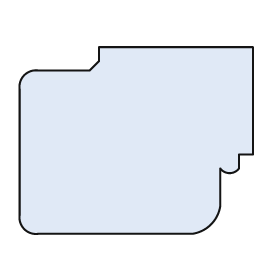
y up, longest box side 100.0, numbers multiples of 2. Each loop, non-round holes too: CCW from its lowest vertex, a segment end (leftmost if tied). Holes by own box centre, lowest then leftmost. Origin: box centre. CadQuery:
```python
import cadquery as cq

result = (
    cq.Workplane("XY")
    .moveTo(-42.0, -40.0)
    .lineTo(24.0, -40.0)
    .threePointArc((32.0, -36.0), (36.0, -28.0))
    .lineTo(36.0, -12.0)
    .threePointArc((40.0, -14.0), (44.0, -12.0))
    .lineTo(44.0, -6.0)
    .lineTo(50.0, -6.0)
    .lineTo(50.0, 40.0)
    .lineTo(-16.0, 40.0)
    .lineTo(-16.0, 34.0)
    .lineTo(-20.0, 30.0)
    .lineTo(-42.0, 30.0)
    .threePointArc((-48.0, 28.0), (-50.0, 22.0))
    .lineTo(-50.0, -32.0)
    .threePointArc((-48.0, -38.0), (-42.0, -40.0))
    .close()
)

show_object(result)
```